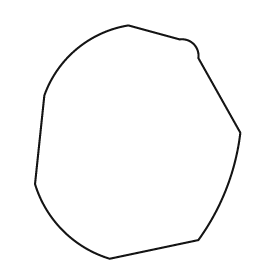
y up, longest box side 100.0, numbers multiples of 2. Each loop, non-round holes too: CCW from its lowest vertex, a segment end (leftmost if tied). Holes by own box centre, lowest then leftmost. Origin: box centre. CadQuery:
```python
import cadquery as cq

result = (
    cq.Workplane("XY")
    .moveTo(-12.0, -50.0)
    .lineTo(26.0, -42.0)
    .threePointArc((38.0, -20.0), (44.0, 4.0))
    .lineTo(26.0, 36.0)
    .threePointArc((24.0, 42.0), (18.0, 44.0))
    .lineTo(-4.0, 50.0)
    .threePointArc((-26.0, 40.0), (-40.0, 20.0))
    .lineTo(-44.0, -18.0)
    .threePointArc((-32.0, -38.0), (-12.0, -50.0))
    .close()
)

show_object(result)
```